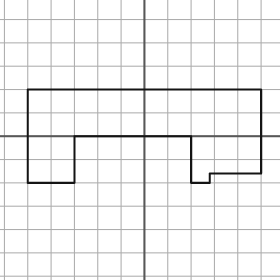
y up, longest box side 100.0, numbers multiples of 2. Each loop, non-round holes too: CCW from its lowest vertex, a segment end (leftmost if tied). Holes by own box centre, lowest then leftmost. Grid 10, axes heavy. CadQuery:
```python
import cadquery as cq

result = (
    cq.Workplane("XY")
    .moveTo(-50.0, -20.0)
    .lineTo(-30.0, -20.0)
    .lineTo(-30.0, 0.0)
    .lineTo(20.0, 0.0)
    .lineTo(20.0, -20.0)
    .lineTo(28.0, -20.0)
    .lineTo(28.0, -16.0)
    .lineTo(50.0, -16.0)
    .lineTo(50.0, 20.0)
    .lineTo(-50.0, 20.0)
    .close()
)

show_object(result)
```